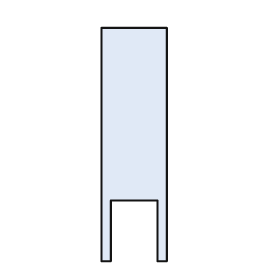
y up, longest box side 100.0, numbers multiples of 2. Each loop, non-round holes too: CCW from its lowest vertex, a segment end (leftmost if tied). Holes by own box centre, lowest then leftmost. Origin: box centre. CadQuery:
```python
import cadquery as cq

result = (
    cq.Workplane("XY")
    .moveTo(-14.0, -50.0)
    .lineTo(-10.0, -50.0)
    .lineTo(-10.0, -24.0)
    .lineTo(10.0, -24.0)
    .lineTo(10.0, -50.0)
    .lineTo(14.0, -50.0)
    .lineTo(14.0, 50.0)
    .lineTo(-14.0, 50.0)
    .close()
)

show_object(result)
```